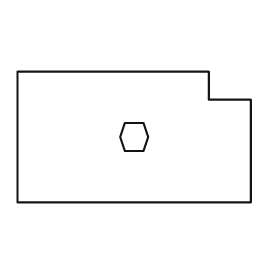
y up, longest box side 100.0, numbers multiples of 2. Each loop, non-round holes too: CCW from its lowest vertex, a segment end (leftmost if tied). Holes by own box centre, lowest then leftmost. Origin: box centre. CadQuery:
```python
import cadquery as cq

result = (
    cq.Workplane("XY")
    .moveTo(-50.0, -28.0)
    .lineTo(50.0, -28.0)
    .lineTo(50.0, 16.0)
    .lineTo(32.0, 16.0)
    .lineTo(32.0, 28.0)
    .lineTo(-50.0, 28.0)
    .close()
    .moveTo(-4.0, -6.0)
    .lineTo(4.0, -6.0)
    .lineTo(6.0, 0.0)
    .lineTo(4.0, 6.0)
    .lineTo(-4.0, 6.0)
    .lineTo(-6.0, 0.0)
    .close()
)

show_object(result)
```